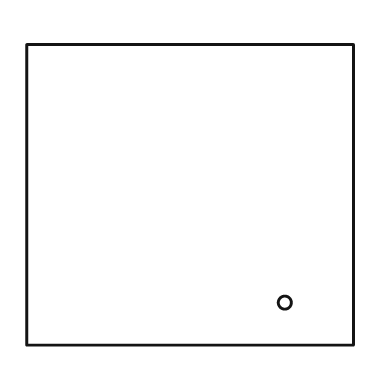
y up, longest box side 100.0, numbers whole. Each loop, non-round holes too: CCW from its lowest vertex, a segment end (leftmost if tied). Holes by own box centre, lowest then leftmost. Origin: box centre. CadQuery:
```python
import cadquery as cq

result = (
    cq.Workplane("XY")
    .moveTo(-50.0, -46.0)
    .lineTo(50.0, -46.0)
    .lineTo(50.0, 46.0)
    .lineTo(-50.0, 46.0)
    .close()
    .moveTo(29.0, -33.0)
    .circle(2.0)
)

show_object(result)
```